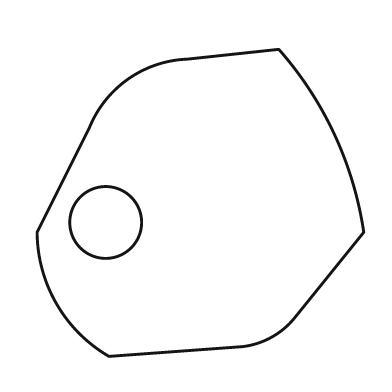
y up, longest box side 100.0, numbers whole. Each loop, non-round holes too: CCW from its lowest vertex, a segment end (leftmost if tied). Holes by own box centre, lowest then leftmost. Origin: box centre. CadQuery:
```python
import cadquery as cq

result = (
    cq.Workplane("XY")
    .moveTo(-28.0, -47.0)
    .lineTo(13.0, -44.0)
    .threePointArc((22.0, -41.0), (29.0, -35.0))
    .lineTo(50.0, -9.0)
    .threePointArc((41.0, 21.0), (24.0, 47.0))
    .lineTo(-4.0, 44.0)
    .threePointArc((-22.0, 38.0), (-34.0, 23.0))
    .lineTo(-50.0, -9.0)
    .threePointArc((-44.0, -31.0), (-28.0, -47.0))
    .close()
    .moveTo(-29.0, -6.0)
    .circle(11.0)
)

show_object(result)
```